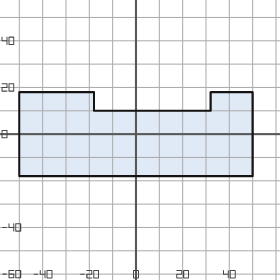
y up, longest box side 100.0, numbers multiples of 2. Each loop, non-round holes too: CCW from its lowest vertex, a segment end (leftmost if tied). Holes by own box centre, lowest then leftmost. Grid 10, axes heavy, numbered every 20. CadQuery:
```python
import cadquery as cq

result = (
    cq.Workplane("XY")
    .moveTo(-50.0, -18.0)
    .lineTo(50.0, -18.0)
    .lineTo(50.0, 18.0)
    .lineTo(32.0, 18.0)
    .lineTo(32.0, 10.0)
    .lineTo(-18.0, 10.0)
    .lineTo(-18.0, 18.0)
    .lineTo(-50.0, 18.0)
    .close()
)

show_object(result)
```